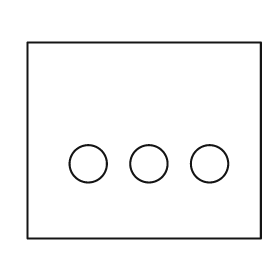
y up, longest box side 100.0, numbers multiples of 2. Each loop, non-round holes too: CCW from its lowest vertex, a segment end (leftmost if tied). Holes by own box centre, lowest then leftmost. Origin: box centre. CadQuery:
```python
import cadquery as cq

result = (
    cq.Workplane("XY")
    .moveTo(-50.0, -42.0)
    .lineTo(50.0, -42.0)
    .lineTo(50.0, 42.0)
    .lineTo(-50.0, 42.0)
    .close()
    .moveTo(-24.0, -10.0)
    .circle(8.0)
    .moveTo(2.0, -10.0)
    .circle(8.0)
    .moveTo(28.0, -10.0)
    .circle(8.0)
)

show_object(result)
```